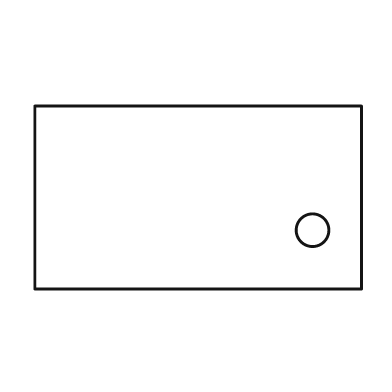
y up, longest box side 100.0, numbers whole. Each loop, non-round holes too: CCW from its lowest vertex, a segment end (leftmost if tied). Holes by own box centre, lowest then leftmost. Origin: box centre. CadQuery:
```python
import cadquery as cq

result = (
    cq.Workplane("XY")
    .moveTo(-50.0, -28.0)
    .lineTo(50.0, -28.0)
    .lineTo(50.0, 28.0)
    .lineTo(-50.0, 28.0)
    .close()
    .moveTo(35.0, -10.0)
    .circle(5.0)
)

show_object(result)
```